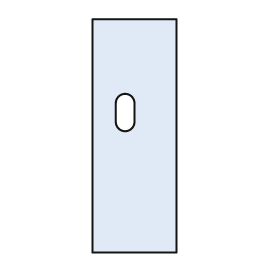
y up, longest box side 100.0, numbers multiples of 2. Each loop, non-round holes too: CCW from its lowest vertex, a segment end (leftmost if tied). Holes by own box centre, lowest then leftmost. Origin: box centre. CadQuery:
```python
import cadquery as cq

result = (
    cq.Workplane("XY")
    .moveTo(-18.0, -50.0)
    .lineTo(18.0, -50.0)
    .lineTo(18.0, 50.0)
    .lineTo(-18.0, 50.0)
    .close()
    .moveTo(-8.0, 6.0)
    .threePointArc((-4.0, 2.0), (0.0, 6.0))
    .lineTo(0.0, 14.0)
    .threePointArc((-4.0, 18.0), (-8.0, 14.0))
    .close()
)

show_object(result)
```